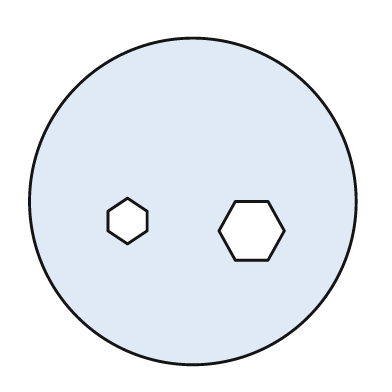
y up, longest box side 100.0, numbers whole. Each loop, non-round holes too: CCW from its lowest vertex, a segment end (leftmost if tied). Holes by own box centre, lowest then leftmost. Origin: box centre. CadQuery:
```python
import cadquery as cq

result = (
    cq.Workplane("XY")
    .moveTo(0.0, 0.0)
    .circle(50.0)
    .moveTo(13.0, -18.0)
    .lineTo(23.0, -18.0)
    .lineTo(28.0, -9.0)
    .lineTo(23.0, 0.0)
    .lineTo(13.0, 0.0)
    .lineTo(8.0, -9.0)
    .close()
    .moveTo(-20.0, -13.0)
    .lineTo(-14.0, -9.0)
    .lineTo(-14.0, -3.0)
    .lineTo(-20.0, 1.0)
    .lineTo(-26.0, -3.0)
    .lineTo(-26.0, -9.0)
    .close()
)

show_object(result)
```